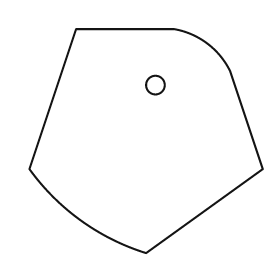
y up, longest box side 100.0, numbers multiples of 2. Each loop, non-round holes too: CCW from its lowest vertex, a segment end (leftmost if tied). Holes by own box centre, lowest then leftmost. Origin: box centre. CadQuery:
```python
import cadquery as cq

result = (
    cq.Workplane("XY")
    .moveTo(0.0, -48.0)
    .lineTo(50.0, -12.0)
    .lineTo(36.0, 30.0)
    .threePointArc((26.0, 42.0), (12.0, 48.0))
    .lineTo(-30.0, 48.0)
    .lineTo(-50.0, -12.0)
    .threePointArc((-28.0, -34.0), (0.0, -48.0))
    .close()
    .moveTo(4.0, 24.0)
    .circle(4.0)
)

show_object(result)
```